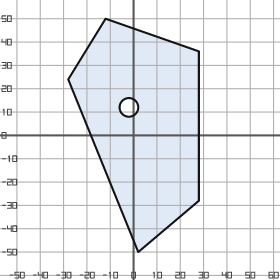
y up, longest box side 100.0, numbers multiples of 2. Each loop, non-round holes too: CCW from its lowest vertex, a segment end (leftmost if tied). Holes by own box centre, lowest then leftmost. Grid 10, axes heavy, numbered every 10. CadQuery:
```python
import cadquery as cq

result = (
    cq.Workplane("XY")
    .moveTo(2.0, -50.0)
    .lineTo(28.0, -28.0)
    .lineTo(28.0, 36.0)
    .lineTo(-12.0, 50.0)
    .lineTo(-28.0, 24.0)
    .close()
    .moveTo(-2.0, 12.0)
    .circle(4.0)
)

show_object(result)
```